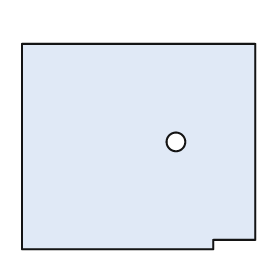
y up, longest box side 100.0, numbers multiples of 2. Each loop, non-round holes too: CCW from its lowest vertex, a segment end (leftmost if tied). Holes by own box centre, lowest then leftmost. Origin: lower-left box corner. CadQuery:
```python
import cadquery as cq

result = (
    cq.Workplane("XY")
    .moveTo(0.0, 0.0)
    .lineTo(82.0, 0.0)
    .lineTo(82.0, 4.0)
    .lineTo(100.0, 4.0)
    .lineTo(100.0, 88.0)
    .lineTo(0.0, 88.0)
    .close()
    .moveTo(66.0, 46.0)
    .circle(4.0)
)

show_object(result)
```